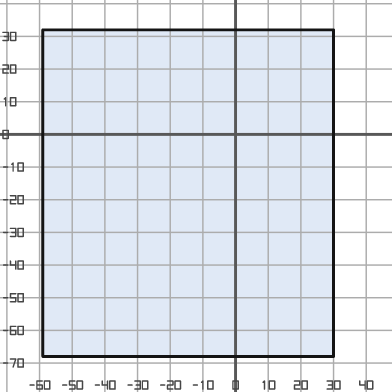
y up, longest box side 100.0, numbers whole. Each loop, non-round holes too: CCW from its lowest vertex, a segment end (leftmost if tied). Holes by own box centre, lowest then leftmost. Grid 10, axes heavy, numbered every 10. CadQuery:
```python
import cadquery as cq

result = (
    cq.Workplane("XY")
    .moveTo(-59.0, -68.0)
    .lineTo(30.0, -68.0)
    .lineTo(30.0, 32.0)
    .lineTo(-59.0, 32.0)
    .close()
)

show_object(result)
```